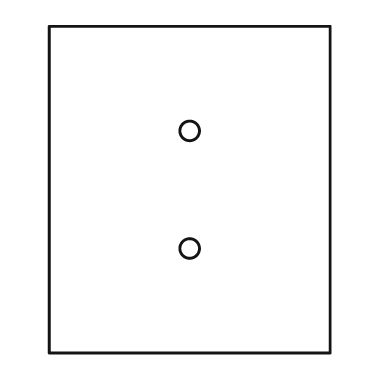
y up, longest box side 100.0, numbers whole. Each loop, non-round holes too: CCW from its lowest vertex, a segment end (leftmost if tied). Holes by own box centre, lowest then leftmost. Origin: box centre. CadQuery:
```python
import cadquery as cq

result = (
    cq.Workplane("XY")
    .moveTo(-43.0, -50.0)
    .lineTo(43.0, -50.0)
    .lineTo(43.0, 50.0)
    .lineTo(-43.0, 50.0)
    .close()
    .moveTo(0.0, -18.0)
    .circle(3.0)
    .moveTo(0.0, 18.0)
    .circle(3.0)
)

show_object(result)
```